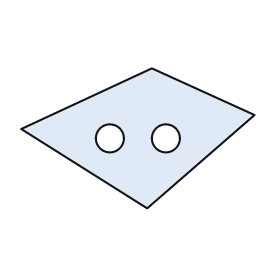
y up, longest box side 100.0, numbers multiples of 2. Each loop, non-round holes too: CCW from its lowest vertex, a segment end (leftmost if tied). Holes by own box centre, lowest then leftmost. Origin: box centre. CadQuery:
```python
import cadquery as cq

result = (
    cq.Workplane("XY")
    .moveTo(4.0, -30.0)
    .lineTo(50.0, 10.0)
    .lineTo(6.0, 30.0)
    .lineTo(-50.0, 4.0)
    .close()
    .moveTo(-12.0, 0.0)
    .circle(6.0)
    .moveTo(12.0, 0.0)
    .circle(6.0)
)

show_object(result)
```